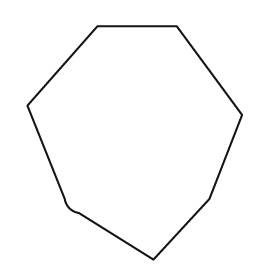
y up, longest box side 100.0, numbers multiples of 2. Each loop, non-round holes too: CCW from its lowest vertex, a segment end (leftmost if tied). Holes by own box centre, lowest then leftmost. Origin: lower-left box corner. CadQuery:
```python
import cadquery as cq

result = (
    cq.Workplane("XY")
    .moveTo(54.0, 0.0)
    .lineTo(78.0, 26.0)
    .lineTo(92.0, 62.0)
    .lineTo(64.0, 100.0)
    .lineTo(30.0, 100.0)
    .lineTo(0.0, 66.0)
    .lineTo(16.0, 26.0)
    .threePointArc((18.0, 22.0), (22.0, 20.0))
    .close()
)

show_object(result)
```